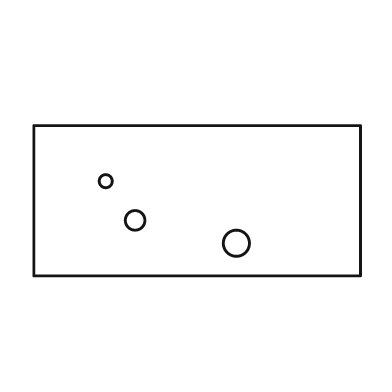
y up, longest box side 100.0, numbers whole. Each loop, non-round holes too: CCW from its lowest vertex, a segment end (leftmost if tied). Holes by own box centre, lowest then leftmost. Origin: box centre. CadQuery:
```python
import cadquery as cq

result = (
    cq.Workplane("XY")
    .moveTo(-50.0, -23.0)
    .lineTo(50.0, -23.0)
    .lineTo(50.0, 23.0)
    .lineTo(-50.0, 23.0)
    .close()
    .moveTo(12.0, -13.0)
    .circle(4.0)
    .moveTo(-19.0, -6.0)
    .circle(3.0)
    .moveTo(-28.0, 6.0)
    .circle(2.0)
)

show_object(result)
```